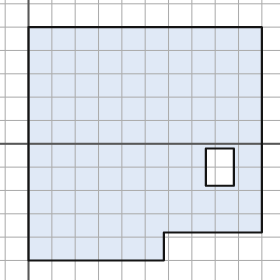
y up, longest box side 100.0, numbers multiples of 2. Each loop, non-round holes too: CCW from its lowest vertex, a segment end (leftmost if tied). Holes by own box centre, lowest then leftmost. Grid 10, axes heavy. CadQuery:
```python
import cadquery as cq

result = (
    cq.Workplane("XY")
    .moveTo(0.0, -50.0)
    .lineTo(58.0, -50.0)
    .lineTo(58.0, -38.0)
    .lineTo(100.0, -38.0)
    .lineTo(100.0, 50.0)
    .lineTo(0.0, 50.0)
    .close()
    .moveTo(76.0, -18.0)
    .lineTo(88.0, -18.0)
    .lineTo(88.0, -2.0)
    .lineTo(76.0, -2.0)
    .close()
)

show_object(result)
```